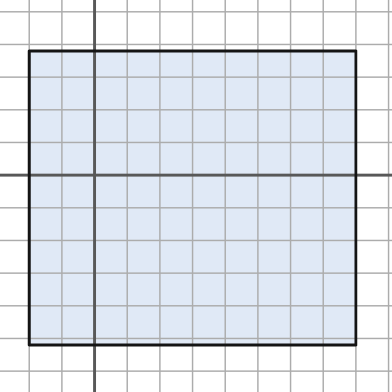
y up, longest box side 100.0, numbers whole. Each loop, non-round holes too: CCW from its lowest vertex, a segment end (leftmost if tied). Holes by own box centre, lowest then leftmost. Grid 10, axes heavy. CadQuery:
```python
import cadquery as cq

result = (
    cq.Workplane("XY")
    .moveTo(-20.0, -52.0)
    .lineTo(80.0, -52.0)
    .lineTo(80.0, 38.0)
    .lineTo(-20.0, 38.0)
    .close()
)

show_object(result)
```